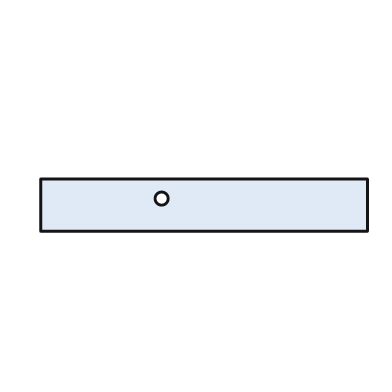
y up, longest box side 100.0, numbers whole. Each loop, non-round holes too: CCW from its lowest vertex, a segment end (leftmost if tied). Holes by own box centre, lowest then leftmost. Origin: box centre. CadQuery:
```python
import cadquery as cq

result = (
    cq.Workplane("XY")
    .moveTo(-50.0, -8.0)
    .lineTo(50.0, -8.0)
    .lineTo(50.0, 8.0)
    .lineTo(-50.0, 8.0)
    .close()
    .moveTo(-13.0, 2.0)
    .circle(2.0)
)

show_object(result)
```